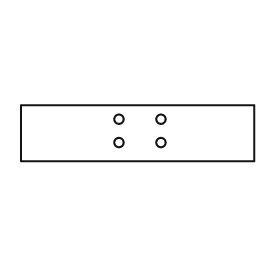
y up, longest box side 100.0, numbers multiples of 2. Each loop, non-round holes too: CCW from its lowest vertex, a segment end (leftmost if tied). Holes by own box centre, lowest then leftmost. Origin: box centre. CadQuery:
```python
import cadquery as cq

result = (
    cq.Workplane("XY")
    .moveTo(-50.0, -12.0)
    .lineTo(50.0, -12.0)
    .lineTo(50.0, 12.0)
    .lineTo(-50.0, 12.0)
    .close()
    .moveTo(-8.0, -4.0)
    .circle(2.0)
    .moveTo(10.0, -4.0)
    .circle(2.0)
    .moveTo(-8.0, 6.0)
    .circle(2.0)
    .moveTo(10.0, 6.0)
    .circle(2.0)
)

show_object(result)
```